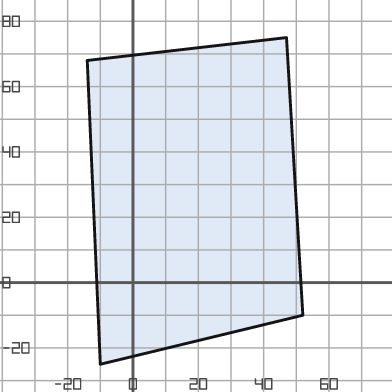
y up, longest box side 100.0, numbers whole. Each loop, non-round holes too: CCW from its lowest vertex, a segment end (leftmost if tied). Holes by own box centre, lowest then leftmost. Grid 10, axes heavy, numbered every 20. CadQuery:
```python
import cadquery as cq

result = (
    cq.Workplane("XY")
    .moveTo(-10.0, -25.0)
    .lineTo(52.0, -10.0)
    .lineTo(47.0, 75.0)
    .lineTo(-14.0, 68.0)
    .close()
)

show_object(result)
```